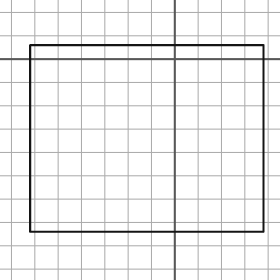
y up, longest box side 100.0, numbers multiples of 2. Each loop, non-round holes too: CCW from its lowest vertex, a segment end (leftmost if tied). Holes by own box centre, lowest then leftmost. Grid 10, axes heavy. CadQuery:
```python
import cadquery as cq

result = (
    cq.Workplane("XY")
    .moveTo(-62.0, -74.0)
    .lineTo(38.0, -74.0)
    .lineTo(38.0, 6.0)
    .lineTo(-62.0, 6.0)
    .close()
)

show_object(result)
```